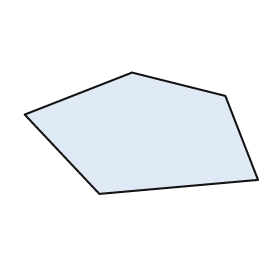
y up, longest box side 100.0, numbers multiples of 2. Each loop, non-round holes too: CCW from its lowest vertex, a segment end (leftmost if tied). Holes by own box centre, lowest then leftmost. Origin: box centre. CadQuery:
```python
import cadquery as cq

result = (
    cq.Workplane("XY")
    .moveTo(-18.0, -26.0)
    .lineTo(50.0, -20.0)
    .lineTo(36.0, 16.0)
    .lineTo(-4.0, 26.0)
    .lineTo(-50.0, 8.0)
    .close()
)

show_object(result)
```